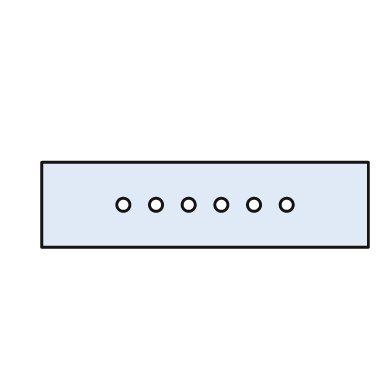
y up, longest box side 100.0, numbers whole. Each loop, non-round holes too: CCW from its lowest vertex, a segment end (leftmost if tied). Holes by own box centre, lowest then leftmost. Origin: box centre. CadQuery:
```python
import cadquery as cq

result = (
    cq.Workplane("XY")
    .moveTo(-50.0, -13.0)
    .lineTo(50.0, -13.0)
    .lineTo(50.0, 13.0)
    .lineTo(-50.0, 13.0)
    .close()
    .moveTo(-25.0, 0.0)
    .circle(2.0)
    .moveTo(-15.0, 0.0)
    .circle(2.0)
    .moveTo(-5.0, 0.0)
    .circle(2.0)
    .moveTo(5.0, 0.0)
    .circle(2.0)
    .moveTo(15.0, 0.0)
    .circle(2.0)
    .moveTo(25.0, 0.0)
    .circle(2.0)
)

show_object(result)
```